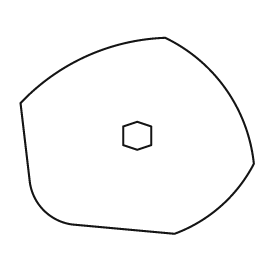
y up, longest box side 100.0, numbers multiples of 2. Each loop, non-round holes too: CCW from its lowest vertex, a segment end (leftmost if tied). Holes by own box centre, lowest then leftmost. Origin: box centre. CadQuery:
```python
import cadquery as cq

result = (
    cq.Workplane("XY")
    .moveTo(16.0, -42.0)
    .threePointArc((36.0, -30.0), (50.0, -12.0))
    .threePointArc((38.0, 20.0), (12.0, 42.0))
    .threePointArc((-22.0, 34.0), (-50.0, 14.0))
    .lineTo(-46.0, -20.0)
    .threePointArc((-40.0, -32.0), (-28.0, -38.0))
    .close()
    .moveTo(0.0, -6.0)
    .lineTo(6.0, -4.0)
    .lineTo(6.0, 4.0)
    .lineTo(0.0, 6.0)
    .lineTo(-6.0, 4.0)
    .lineTo(-6.0, -4.0)
    .close()
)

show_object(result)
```